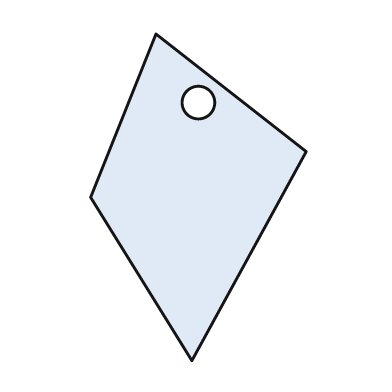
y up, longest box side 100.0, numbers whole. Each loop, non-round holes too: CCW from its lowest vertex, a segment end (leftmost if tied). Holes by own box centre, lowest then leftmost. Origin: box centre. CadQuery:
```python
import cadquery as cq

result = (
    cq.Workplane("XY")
    .moveTo(-2.0, -50.0)
    .lineTo(33.0, 14.0)
    .lineTo(-13.0, 50.0)
    .lineTo(-33.0, 0.0)
    .close()
    .moveTo(0.0, 29.0)
    .circle(5.0)
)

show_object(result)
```